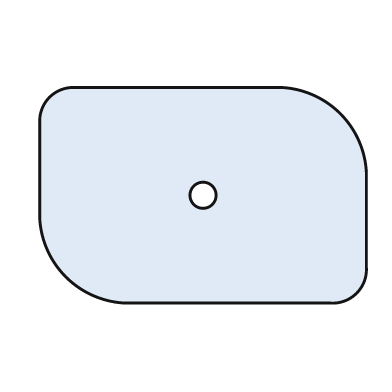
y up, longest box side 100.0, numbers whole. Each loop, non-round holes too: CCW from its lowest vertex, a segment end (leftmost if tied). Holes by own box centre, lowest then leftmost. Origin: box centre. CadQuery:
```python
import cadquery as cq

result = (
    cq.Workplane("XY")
    .moveTo(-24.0, -33.0)
    .lineTo(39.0, -33.0)
    .threePointArc((47.0, -30.0), (50.0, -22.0))
    .lineTo(50.0, 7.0)
    .threePointArc((42.0, 25.0), (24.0, 33.0))
    .lineTo(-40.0, 33.0)
    .threePointArc((-47.0, 30.0), (-50.0, 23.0))
    .lineTo(-50.0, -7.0)
    .threePointArc((-42.0, -25.0), (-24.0, -33.0))
    .close()
    .moveTo(0.0, 0.0)
    .circle(4.0)
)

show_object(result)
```